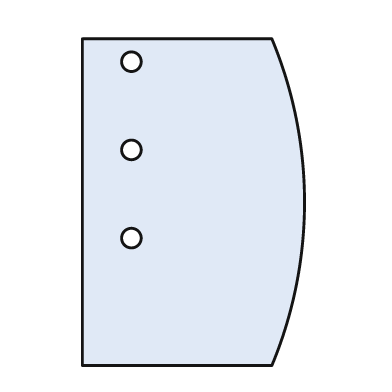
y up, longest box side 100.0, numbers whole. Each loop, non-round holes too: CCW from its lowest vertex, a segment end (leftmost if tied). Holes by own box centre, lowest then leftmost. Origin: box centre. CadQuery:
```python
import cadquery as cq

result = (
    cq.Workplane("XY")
    .moveTo(-34.0, -50.0)
    .lineTo(24.0, -50.0)
    .threePointArc((34.0, 0.0), (24.0, 50.0))
    .lineTo(-34.0, 50.0)
    .close()
    .moveTo(-19.0, -11.0)
    .circle(3.0)
    .moveTo(-19.0, 16.0)
    .circle(3.0)
    .moveTo(-19.0, 43.0)
    .circle(3.0)
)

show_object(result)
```